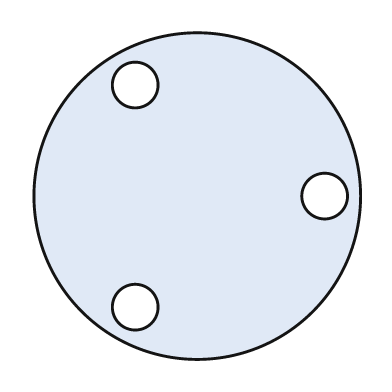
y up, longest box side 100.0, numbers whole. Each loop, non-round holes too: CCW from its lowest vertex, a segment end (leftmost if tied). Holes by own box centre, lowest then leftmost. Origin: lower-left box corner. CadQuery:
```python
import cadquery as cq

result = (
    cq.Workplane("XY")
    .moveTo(50.0, 50.0)
    .circle(50.0)
    .moveTo(31.0, 16.0)
    .circle(7.0)
    .moveTo(89.0, 50.0)
    .circle(7.0)
    .moveTo(31.0, 84.0)
    .circle(7.0)
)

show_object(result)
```